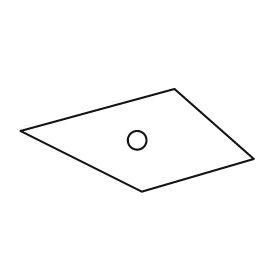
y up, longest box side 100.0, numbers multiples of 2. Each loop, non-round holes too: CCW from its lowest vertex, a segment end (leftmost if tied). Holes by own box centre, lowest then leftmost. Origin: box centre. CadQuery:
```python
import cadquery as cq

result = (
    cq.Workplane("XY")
    .moveTo(2.0, -22.0)
    .lineTo(50.0, -8.0)
    .lineTo(16.0, 22.0)
    .lineTo(-50.0, 4.0)
    .close()
    .moveTo(0.0, 0.0)
    .circle(4.0)
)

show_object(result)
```